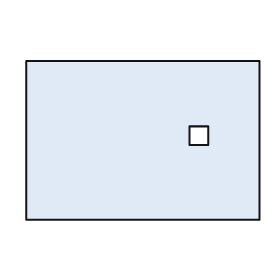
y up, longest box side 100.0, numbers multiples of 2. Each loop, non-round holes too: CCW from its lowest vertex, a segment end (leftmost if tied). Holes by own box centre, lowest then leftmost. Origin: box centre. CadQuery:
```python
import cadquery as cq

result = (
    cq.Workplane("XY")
    .moveTo(-50.0, -34.0)
    .lineTo(50.0, -34.0)
    .lineTo(50.0, 34.0)
    .lineTo(-50.0, 34.0)
    .close()
    .moveTo(20.0, -2.0)
    .lineTo(28.0, -2.0)
    .lineTo(28.0, 6.0)
    .lineTo(20.0, 6.0)
    .close()
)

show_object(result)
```